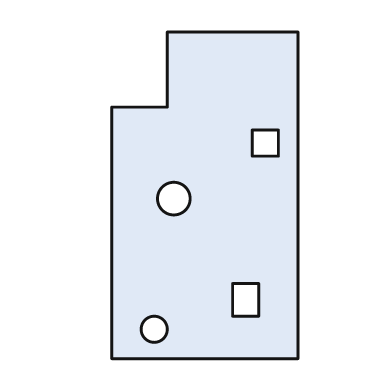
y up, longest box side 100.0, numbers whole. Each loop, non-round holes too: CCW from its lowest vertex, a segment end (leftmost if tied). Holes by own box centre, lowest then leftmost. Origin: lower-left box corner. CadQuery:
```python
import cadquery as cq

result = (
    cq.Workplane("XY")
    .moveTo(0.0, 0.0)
    .lineTo(57.0, 0.0)
    .lineTo(57.0, 100.0)
    .lineTo(17.0, 100.0)
    .lineTo(17.0, 77.0)
    .lineTo(0.0, 77.0)
    .close()
    .moveTo(13.0, 9.0)
    .circle(4.0)
    .moveTo(37.0, 13.0)
    .lineTo(45.0, 13.0)
    .lineTo(45.0, 23.0)
    .lineTo(37.0, 23.0)
    .close()
    .moveTo(19.0, 49.0)
    .circle(5.0)
    .moveTo(43.0, 62.0)
    .lineTo(51.0, 62.0)
    .lineTo(51.0, 70.0)
    .lineTo(43.0, 70.0)
    .close()
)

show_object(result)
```